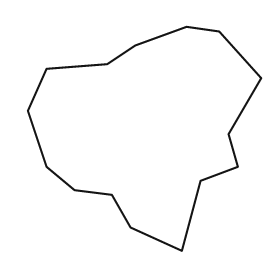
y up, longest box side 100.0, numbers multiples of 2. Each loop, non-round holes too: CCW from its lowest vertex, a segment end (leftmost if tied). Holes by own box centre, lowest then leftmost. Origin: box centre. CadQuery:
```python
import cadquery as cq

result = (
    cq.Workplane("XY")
    .moveTo(16.0, -48.0)
    .lineTo(24.0, -18.0)
    .lineTo(40.0, -12.0)
    .lineTo(36.0, 2.0)
    .lineTo(50.0, 26.0)
    .lineTo(32.0, 46.0)
    .lineTo(18.0, 48.0)
    .lineTo(-4.0, 40.0)
    .lineTo(-16.0, 32.0)
    .lineTo(-42.0, 30.0)
    .lineTo(-50.0, 12.0)
    .lineTo(-42.0, -12.0)
    .lineTo(-30.0, -22.0)
    .lineTo(-14.0, -24.0)
    .lineTo(-6.0, -38.0)
    .close()
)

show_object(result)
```